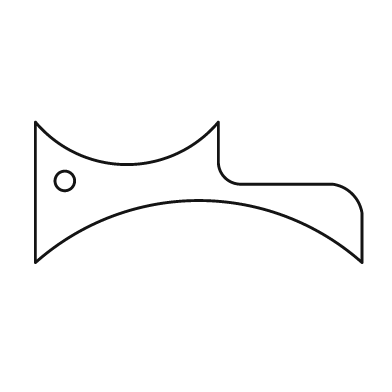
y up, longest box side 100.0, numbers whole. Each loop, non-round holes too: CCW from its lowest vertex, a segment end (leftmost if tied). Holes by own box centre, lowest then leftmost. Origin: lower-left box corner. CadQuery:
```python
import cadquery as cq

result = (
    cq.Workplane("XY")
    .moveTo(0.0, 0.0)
    .threePointArc((50.0, 19.0), (100.0, 0.0))
    .lineTo(100.0, 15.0)
    .threePointArc((97.0, 21.0), (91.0, 24.0))
    .lineTo(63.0, 24.0)
    .threePointArc((58.0, 26.0), (56.0, 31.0))
    .lineTo(56.0, 43.0)
    .threePointArc((28.0, 30.0), (0.0, 43.0))
    .close()
    .moveTo(9.0, 25.0)
    .circle(3.0)
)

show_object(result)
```